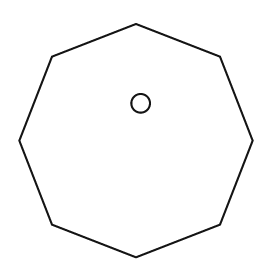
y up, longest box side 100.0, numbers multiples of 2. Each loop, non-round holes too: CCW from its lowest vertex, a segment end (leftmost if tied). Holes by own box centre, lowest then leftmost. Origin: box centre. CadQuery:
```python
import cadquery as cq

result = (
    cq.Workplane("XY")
    .moveTo(0.0, -50.0)
    .lineTo(36.0, -36.0)
    .lineTo(50.0, 0.0)
    .lineTo(36.0, 36.0)
    .lineTo(0.0, 50.0)
    .lineTo(-36.0, 36.0)
    .lineTo(-50.0, 0.0)
    .lineTo(-36.0, -36.0)
    .close()
    .moveTo(2.0, 16.0)
    .circle(4.0)
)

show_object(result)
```